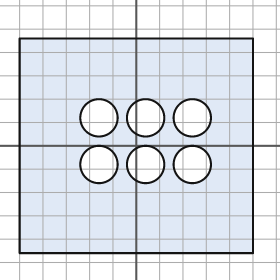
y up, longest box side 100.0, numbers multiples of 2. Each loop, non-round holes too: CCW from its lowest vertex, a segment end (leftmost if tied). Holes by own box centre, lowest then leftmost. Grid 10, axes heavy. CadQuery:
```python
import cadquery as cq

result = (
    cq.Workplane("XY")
    .moveTo(-50.0, -46.0)
    .lineTo(50.0, -46.0)
    .lineTo(50.0, 46.0)
    .lineTo(-50.0, 46.0)
    .close()
    .moveTo(-16.0, -8.0)
    .circle(8.0)
    .moveTo(4.0, -8.0)
    .circle(8.0)
    .moveTo(24.0, -8.0)
    .circle(8.0)
    .moveTo(-16.0, 12.0)
    .circle(8.0)
    .moveTo(4.0, 12.0)
    .circle(8.0)
    .moveTo(24.0, 12.0)
    .circle(8.0)
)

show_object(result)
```